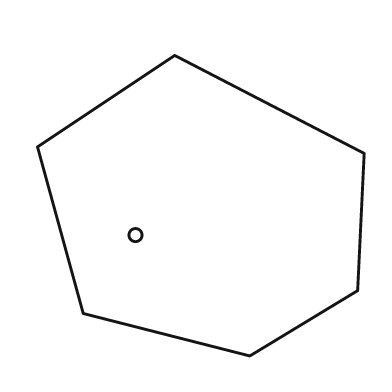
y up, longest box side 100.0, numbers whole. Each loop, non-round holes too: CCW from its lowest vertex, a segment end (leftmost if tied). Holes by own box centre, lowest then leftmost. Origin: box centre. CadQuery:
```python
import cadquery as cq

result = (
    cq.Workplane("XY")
    .moveTo(15.0, -46.0)
    .lineTo(48.0, -26.0)
    .lineTo(50.0, 16.0)
    .lineTo(-8.0, 46.0)
    .lineTo(-50.0, 18.0)
    .lineTo(-36.0, -33.0)
    .close()
    .moveTo(-20.0, -9.0)
    .circle(2.0)
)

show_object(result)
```